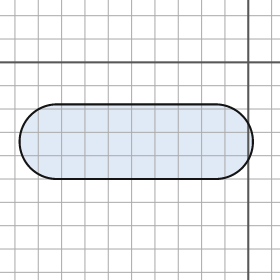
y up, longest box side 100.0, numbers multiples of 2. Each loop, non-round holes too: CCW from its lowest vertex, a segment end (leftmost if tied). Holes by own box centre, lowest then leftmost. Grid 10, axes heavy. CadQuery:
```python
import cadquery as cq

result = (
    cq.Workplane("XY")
    .moveTo(-82.0, -50.0)
    .lineTo(-14.0, -50.0)
    .threePointArc((2.0, -34.0), (-14.0, -18.0))
    .lineTo(-82.0, -18.0)
    .threePointArc((-98.0, -34.0), (-82.0, -50.0))
    .close()
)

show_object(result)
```